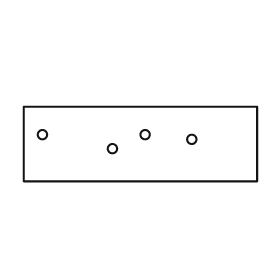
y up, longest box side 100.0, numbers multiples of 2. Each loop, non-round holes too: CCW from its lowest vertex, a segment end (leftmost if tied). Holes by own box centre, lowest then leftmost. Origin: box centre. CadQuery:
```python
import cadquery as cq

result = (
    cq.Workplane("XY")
    .moveTo(-50.0, -16.0)
    .lineTo(50.0, -16.0)
    .lineTo(50.0, 16.0)
    .lineTo(-50.0, 16.0)
    .close()
    .moveTo(-12.0, -2.0)
    .circle(2.0)
    .moveTo(22.0, 2.0)
    .circle(2.0)
    .moveTo(-42.0, 4.0)
    .circle(2.0)
    .moveTo(2.0, 4.0)
    .circle(2.0)
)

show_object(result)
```